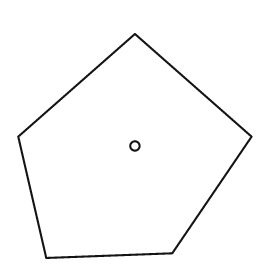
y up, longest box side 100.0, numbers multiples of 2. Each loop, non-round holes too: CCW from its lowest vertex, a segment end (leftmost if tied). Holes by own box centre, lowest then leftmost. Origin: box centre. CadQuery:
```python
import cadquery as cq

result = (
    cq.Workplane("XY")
    .moveTo(-38.0, -48.0)
    .lineTo(16.0, -46.0)
    .lineTo(50.0, 4.0)
    .lineTo(0.0, 48.0)
    .lineTo(-50.0, 4.0)
    .close()
    .moveTo(0.0, 0.0)
    .circle(2.0)
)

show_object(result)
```